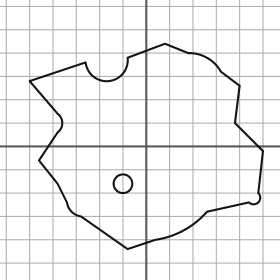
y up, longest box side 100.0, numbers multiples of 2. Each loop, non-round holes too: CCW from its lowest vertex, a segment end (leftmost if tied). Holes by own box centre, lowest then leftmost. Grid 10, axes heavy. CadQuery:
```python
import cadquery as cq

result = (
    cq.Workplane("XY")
    .moveTo(-8.0, -44.0)
    .lineTo(4.0, -40.0)
    .threePointArc((16.0, -36.0), (26.0, -28.0))
    .lineTo(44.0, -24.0)
    .threePointArc((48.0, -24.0), (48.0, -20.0))
    .lineTo(50.0, -2.0)
    .lineTo(38.0, 10.0)
    .lineTo(40.0, 26.0)
    .lineTo(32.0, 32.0)
    .threePointArc((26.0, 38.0), (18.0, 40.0))
    .lineTo(8.0, 44.0)
    .lineTo(-8.0, 38.0)
    .threePointArc((-16.0, 28.0), (-26.0, 36.0))
    .lineTo(-50.0, 28.0)
    .lineTo(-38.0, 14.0)
    .threePointArc((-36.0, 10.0), (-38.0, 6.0))
    .lineTo(-46.0, -6.0)
    .lineTo(-38.0, -16.0)
    .lineTo(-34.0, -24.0)
    .threePointArc((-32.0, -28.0), (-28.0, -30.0))
    .close()
    .moveTo(-10.0, -16.0)
    .circle(4.0)
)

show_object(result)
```